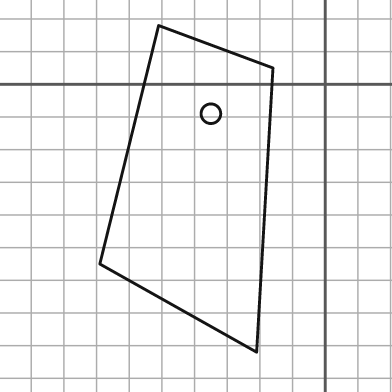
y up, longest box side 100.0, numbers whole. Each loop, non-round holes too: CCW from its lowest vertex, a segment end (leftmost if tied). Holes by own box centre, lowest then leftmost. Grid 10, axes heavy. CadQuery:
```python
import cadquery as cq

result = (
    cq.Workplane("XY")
    .moveTo(-21.0, -82.0)
    .lineTo(-16.0, 5.0)
    .lineTo(-51.0, 18.0)
    .lineTo(-69.0, -55.0)
    .close()
    .moveTo(-35.0, -9.0)
    .circle(3.0)
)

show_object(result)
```